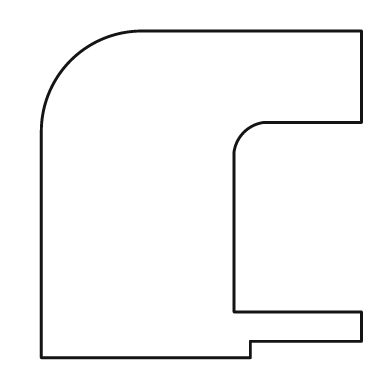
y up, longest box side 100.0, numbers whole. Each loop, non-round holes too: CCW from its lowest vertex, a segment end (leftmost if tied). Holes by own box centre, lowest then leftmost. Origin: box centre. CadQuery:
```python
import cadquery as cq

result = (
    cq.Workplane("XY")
    .moveTo(-49.0, -50.0)
    .lineTo(15.0, -50.0)
    .lineTo(15.0, -45.0)
    .lineTo(49.0, -45.0)
    .lineTo(49.0, -36.0)
    .lineTo(10.0, -36.0)
    .lineTo(10.0, 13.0)
    .threePointArc((13.0, 19.0), (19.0, 22.0))
    .lineTo(49.0, 22.0)
    .lineTo(49.0, 50.0)
    .lineTo(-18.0, 50.0)
    .threePointArc((-40.0, 41.0), (-49.0, 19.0))
    .close()
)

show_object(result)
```